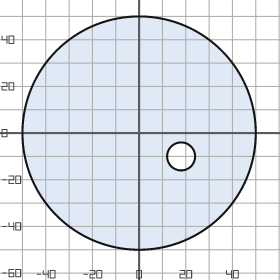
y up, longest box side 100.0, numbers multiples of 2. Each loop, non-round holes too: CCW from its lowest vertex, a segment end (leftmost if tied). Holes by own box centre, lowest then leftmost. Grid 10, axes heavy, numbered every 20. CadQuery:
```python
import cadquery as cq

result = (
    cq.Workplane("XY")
    .moveTo(0.0, 0.0)
    .circle(50.0)
    .moveTo(18.0, -10.0)
    .circle(6.0)
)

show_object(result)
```